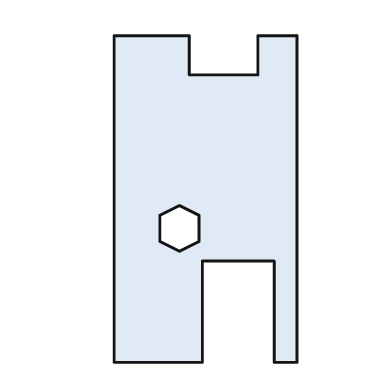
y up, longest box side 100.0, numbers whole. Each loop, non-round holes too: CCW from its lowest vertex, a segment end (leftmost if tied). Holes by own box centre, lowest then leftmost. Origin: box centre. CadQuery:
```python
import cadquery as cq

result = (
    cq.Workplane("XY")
    .moveTo(-28.0, -50.0)
    .lineTo(-1.0, -50.0)
    .lineTo(-1.0, -19.0)
    .lineTo(21.0, -19.0)
    .lineTo(21.0, -50.0)
    .lineTo(28.0, -50.0)
    .lineTo(28.0, 50.0)
    .lineTo(16.0, 50.0)
    .lineTo(16.0, 38.0)
    .lineTo(-5.0, 38.0)
    .lineTo(-5.0, 50.0)
    .lineTo(-28.0, 50.0)
    .close()
    .moveTo(-8.0, -16.0)
    .lineTo(-2.0, -13.0)
    .lineTo(-2.0, -5.0)
    .lineTo(-8.0, -2.0)
    .lineTo(-14.0, -5.0)
    .lineTo(-14.0, -13.0)
    .close()
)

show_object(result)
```